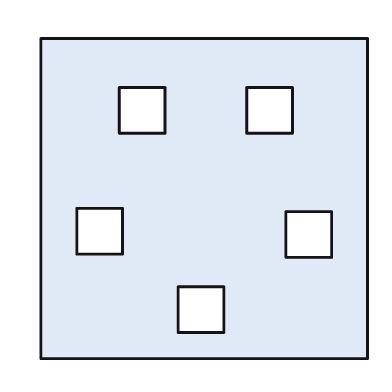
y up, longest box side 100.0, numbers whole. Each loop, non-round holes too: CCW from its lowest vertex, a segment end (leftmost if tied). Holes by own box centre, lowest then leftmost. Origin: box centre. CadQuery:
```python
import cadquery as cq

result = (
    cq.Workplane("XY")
    .moveTo(-50.0, -49.0)
    .lineTo(50.0, -49.0)
    .lineTo(50.0, 49.0)
    .lineTo(-50.0, 49.0)
    .close()
    .moveTo(-8.0, -41.0)
    .lineTo(6.0, -41.0)
    .lineTo(6.0, -27.0)
    .lineTo(-8.0, -27.0)
    .close()
    .moveTo(25.0, -18.0)
    .lineTo(39.0, -18.0)
    .lineTo(39.0, -4.0)
    .lineTo(25.0, -4.0)
    .close()
    .moveTo(-39.0, -17.0)
    .lineTo(-25.0, -17.0)
    .lineTo(-25.0, -3.0)
    .lineTo(-39.0, -3.0)
    .close()
    .moveTo(-26.0, 20.0)
    .lineTo(-12.0, 20.0)
    .lineTo(-12.0, 34.0)
    .lineTo(-26.0, 34.0)
    .close()
    .moveTo(13.0, 20.0)
    .lineTo(27.0, 20.0)
    .lineTo(27.0, 34.0)
    .lineTo(13.0, 34.0)
    .close()
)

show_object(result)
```